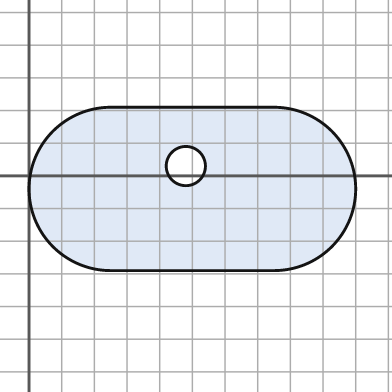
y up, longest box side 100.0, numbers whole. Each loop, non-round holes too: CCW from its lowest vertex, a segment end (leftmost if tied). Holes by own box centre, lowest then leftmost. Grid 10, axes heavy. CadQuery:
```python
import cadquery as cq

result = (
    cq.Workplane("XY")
    .moveTo(25.0, -29.0)
    .lineTo(75.0, -29.0)
    .threePointArc((100.0, -4.0), (75.0, 21.0))
    .lineTo(25.0, 21.0)
    .threePointArc((0.0, -4.0), (25.0, -29.0))
    .close()
    .moveTo(48.0, 3.0)
    .circle(6.0)
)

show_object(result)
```